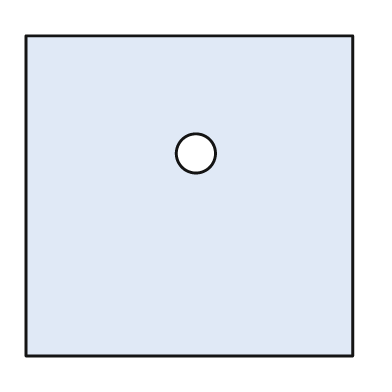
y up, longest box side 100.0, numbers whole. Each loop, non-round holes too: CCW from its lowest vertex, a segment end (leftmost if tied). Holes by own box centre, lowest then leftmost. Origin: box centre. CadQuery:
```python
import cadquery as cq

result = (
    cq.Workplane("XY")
    .moveTo(-50.0, -49.0)
    .lineTo(50.0, -49.0)
    .lineTo(50.0, 49.0)
    .lineTo(-50.0, 49.0)
    .close()
    .moveTo(2.0, 13.0)
    .circle(6.0)
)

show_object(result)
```